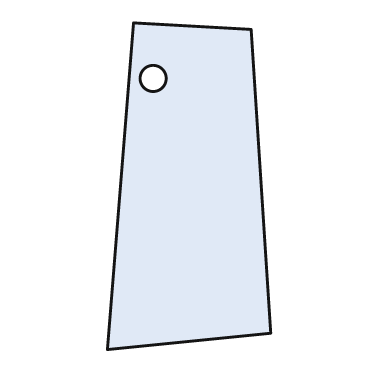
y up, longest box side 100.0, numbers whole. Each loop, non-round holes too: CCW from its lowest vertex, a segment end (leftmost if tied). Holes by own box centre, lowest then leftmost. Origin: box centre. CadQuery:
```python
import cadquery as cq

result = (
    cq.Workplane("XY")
    .moveTo(-25.0, -50.0)
    .lineTo(25.0, -45.0)
    .lineTo(19.0, 48.0)
    .lineTo(-17.0, 50.0)
    .close()
    .moveTo(-11.0, 33.0)
    .circle(4.0)
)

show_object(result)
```